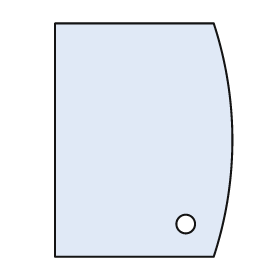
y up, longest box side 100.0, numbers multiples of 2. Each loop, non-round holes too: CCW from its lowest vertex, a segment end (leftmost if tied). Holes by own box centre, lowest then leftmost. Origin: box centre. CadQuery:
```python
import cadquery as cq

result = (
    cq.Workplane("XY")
    .moveTo(-38.0, -50.0)
    .lineTo(30.0, -50.0)
    .threePointArc((38.0, 0.0), (30.0, 50.0))
    .lineTo(-38.0, 50.0)
    .close()
    .moveTo(18.0, -36.0)
    .circle(4.0)
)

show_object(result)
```